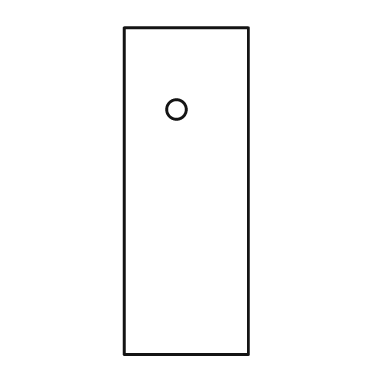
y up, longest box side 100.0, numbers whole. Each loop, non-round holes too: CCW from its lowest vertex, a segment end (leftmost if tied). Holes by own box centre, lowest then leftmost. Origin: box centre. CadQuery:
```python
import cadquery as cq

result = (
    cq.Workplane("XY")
    .moveTo(-19.0, -50.0)
    .lineTo(19.0, -50.0)
    .lineTo(19.0, 50.0)
    .lineTo(-19.0, 50.0)
    .close()
    .moveTo(-3.0, 25.0)
    .circle(3.0)
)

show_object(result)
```